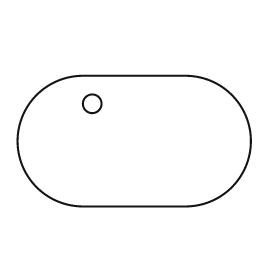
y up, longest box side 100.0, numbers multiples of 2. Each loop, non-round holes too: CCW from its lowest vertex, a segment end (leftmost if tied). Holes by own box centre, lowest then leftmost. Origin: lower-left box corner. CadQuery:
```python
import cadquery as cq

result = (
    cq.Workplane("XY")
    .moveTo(28.0, 0.0)
    .lineTo(72.0, 0.0)
    .threePointArc((100.0, 28.0), (72.0, 56.0))
    .lineTo(28.0, 56.0)
    .threePointArc((0.0, 28.0), (28.0, 0.0))
    .close()
    .moveTo(32.0, 44.0)
    .circle(4.0)
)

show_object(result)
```